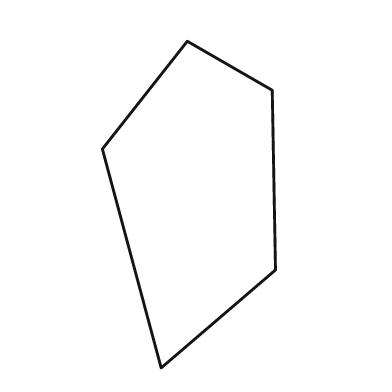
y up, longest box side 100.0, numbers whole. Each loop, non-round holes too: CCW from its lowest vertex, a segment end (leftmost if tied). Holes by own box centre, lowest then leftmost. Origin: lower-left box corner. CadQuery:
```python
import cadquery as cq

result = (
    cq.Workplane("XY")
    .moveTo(18.0, 0.0)
    .lineTo(53.0, 30.0)
    .lineTo(52.0, 85.0)
    .lineTo(26.0, 100.0)
    .lineTo(0.0, 67.0)
    .close()
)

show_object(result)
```